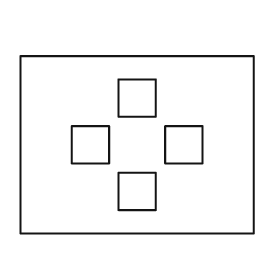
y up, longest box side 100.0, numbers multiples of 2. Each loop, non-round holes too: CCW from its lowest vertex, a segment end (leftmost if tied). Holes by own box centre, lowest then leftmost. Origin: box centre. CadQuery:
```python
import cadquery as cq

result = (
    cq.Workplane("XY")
    .moveTo(-50.0, -38.0)
    .lineTo(50.0, -38.0)
    .lineTo(50.0, 38.0)
    .lineTo(-50.0, 38.0)
    .close()
    .moveTo(-8.0, -28.0)
    .lineTo(8.0, -28.0)
    .lineTo(8.0, -12.0)
    .lineTo(-8.0, -12.0)
    .close()
    .moveTo(-28.0, -8.0)
    .lineTo(-12.0, -8.0)
    .lineTo(-12.0, 8.0)
    .lineTo(-28.0, 8.0)
    .close()
    .moveTo(12.0, -8.0)
    .lineTo(28.0, -8.0)
    .lineTo(28.0, 8.0)
    .lineTo(12.0, 8.0)
    .close()
    .moveTo(-8.0, 12.0)
    .lineTo(8.0, 12.0)
    .lineTo(8.0, 28.0)
    .lineTo(-8.0, 28.0)
    .close()
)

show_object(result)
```